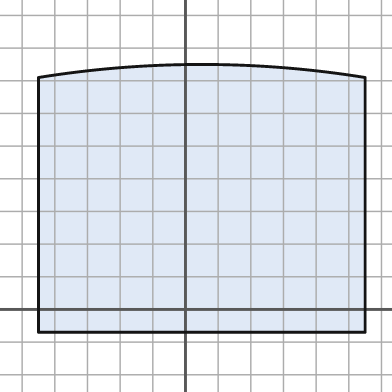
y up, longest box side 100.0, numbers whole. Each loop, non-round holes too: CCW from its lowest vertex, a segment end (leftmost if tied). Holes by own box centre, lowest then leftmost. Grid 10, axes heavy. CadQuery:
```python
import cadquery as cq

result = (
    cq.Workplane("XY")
    .moveTo(-45.0, -7.0)
    .lineTo(55.0, -7.0)
    .lineTo(55.0, 71.0)
    .threePointArc((5.0, 75.0), (-45.0, 71.0))
    .close()
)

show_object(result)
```